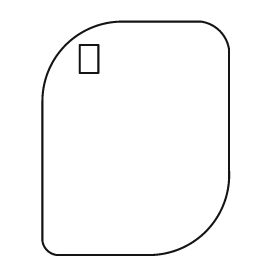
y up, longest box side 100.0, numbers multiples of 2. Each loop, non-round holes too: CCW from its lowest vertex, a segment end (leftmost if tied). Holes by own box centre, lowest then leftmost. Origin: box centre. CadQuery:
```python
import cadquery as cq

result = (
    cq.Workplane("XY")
    .moveTo(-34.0, -50.0)
    .lineTo(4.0, -50.0)
    .threePointArc((30.0, -40.0), (40.0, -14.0))
    .lineTo(40.0, 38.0)
    .threePointArc((36.0, 46.0), (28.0, 50.0))
    .lineTo(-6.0, 50.0)
    .threePointArc((-30.0, 40.0), (-40.0, 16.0))
    .lineTo(-40.0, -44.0)
    .threePointArc((-38.0, -48.0), (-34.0, -50.0))
    .close()
    .moveTo(-24.0, 28.0)
    .lineTo(-16.0, 28.0)
    .lineTo(-16.0, 40.0)
    .lineTo(-24.0, 40.0)
    .close()
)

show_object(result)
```